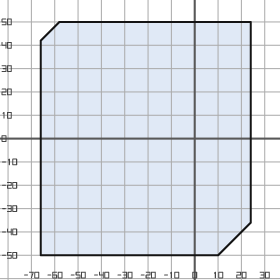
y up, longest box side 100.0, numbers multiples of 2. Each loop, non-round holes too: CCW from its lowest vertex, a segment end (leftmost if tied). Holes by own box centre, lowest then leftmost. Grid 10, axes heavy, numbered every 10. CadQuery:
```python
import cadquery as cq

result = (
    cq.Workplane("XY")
    .moveTo(-66.0, -50.0)
    .lineTo(10.0, -50.0)
    .lineTo(24.0, -36.0)
    .lineTo(24.0, 50.0)
    .lineTo(-58.0, 50.0)
    .lineTo(-66.0, 42.0)
    .close()
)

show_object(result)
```